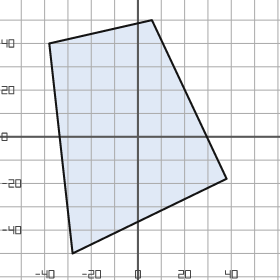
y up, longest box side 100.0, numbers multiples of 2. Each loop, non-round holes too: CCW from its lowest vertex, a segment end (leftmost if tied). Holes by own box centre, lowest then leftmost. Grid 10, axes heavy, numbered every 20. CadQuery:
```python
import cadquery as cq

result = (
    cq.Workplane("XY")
    .moveTo(-28.0, -50.0)
    .lineTo(38.0, -18.0)
    .lineTo(6.0, 50.0)
    .lineTo(-38.0, 40.0)
    .close()
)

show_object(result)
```